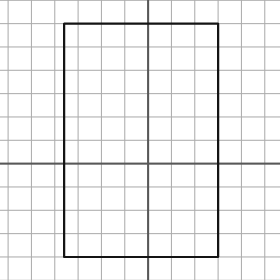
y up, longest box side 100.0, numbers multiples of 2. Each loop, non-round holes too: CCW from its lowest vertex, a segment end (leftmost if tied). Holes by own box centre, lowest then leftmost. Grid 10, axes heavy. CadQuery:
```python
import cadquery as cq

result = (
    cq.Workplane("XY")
    .moveTo(-36.0, -40.0)
    .lineTo(30.0, -40.0)
    .lineTo(30.0, 60.0)
    .lineTo(-36.0, 60.0)
    .close()
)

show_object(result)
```